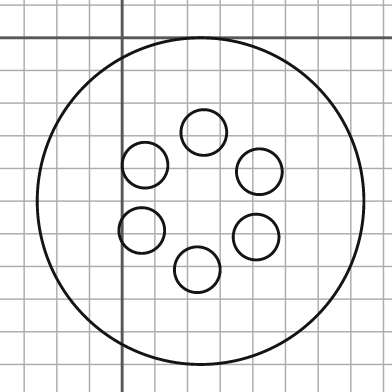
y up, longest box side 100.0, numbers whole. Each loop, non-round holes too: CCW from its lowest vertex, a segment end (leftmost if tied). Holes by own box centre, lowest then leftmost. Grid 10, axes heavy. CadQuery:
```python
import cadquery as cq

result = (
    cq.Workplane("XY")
    .moveTo(24.0, -50.0)
    .circle(50.0)
    .moveTo(23.0, -71.0)
    .circle(7.0)
    .moveTo(41.0, -61.0)
    .circle(7.0)
    .moveTo(6.0, -59.0)
    .circle(7.0)
    .moveTo(42.0, -41.0)
    .circle(7.0)
    .moveTo(7.0, -39.0)
    .circle(7.0)
    .moveTo(25.0, -29.0)
    .circle(7.0)
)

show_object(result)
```